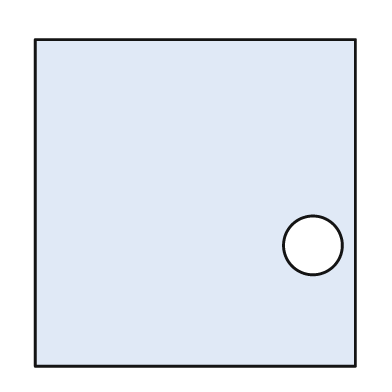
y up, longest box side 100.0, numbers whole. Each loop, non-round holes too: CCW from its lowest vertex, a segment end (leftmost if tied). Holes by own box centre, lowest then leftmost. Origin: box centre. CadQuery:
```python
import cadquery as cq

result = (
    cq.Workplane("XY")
    .moveTo(-49.0, -50.0)
    .lineTo(49.0, -50.0)
    .lineTo(49.0, 50.0)
    .lineTo(-49.0, 50.0)
    .close()
    .moveTo(36.0, -13.0)
    .circle(9.0)
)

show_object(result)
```